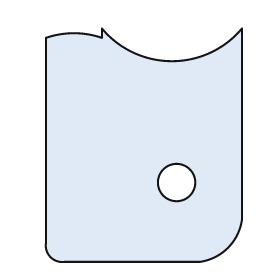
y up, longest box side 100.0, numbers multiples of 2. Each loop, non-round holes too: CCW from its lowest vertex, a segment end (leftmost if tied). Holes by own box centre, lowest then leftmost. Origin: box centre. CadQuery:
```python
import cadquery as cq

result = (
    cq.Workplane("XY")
    .moveTo(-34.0, -50.0)
    .lineTo(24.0, -50.0)
    .threePointArc((36.0, -44.0), (42.0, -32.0))
    .lineTo(42.0, 50.0)
    .threePointArc((12.0, 36.0), (-18.0, 50.0))
    .lineTo(-18.0, 46.0)
    .threePointArc((-30.0, 48.0), (-42.0, 46.0))
    .lineTo(-42.0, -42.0)
    .threePointArc((-40.0, -48.0), (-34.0, -50.0))
    .close()
    .moveTo(14.0, -16.0)
    .circle(8.0)
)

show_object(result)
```